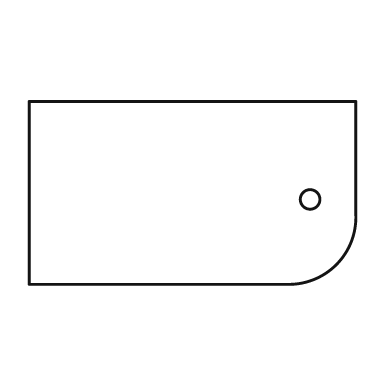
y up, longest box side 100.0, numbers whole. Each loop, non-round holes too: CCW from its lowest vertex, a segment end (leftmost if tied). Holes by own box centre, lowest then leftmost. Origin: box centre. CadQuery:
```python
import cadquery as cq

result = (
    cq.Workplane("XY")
    .moveTo(-50.0, -28.0)
    .lineTo(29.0, -28.0)
    .threePointArc((44.0, -22.0), (50.0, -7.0))
    .lineTo(50.0, 28.0)
    .lineTo(-50.0, 28.0)
    .close()
    .moveTo(36.0, -2.0)
    .circle(3.0)
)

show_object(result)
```